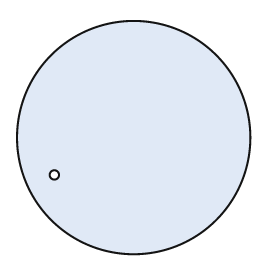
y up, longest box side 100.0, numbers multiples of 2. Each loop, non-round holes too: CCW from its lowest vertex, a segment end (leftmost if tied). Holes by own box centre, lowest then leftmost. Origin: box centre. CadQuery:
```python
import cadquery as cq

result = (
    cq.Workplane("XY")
    .moveTo(0.0, 0.0)
    .circle(50.0)
    .moveTo(-34.0, -16.0)
    .circle(2.0)
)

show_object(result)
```